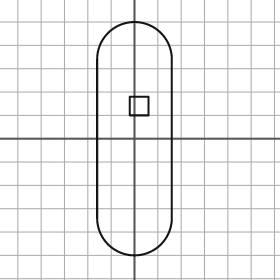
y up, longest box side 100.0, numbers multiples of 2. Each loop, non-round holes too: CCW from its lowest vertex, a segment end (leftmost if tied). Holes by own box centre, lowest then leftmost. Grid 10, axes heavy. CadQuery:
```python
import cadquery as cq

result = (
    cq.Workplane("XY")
    .moveTo(-16.0, -34.0)
    .threePointArc((0.0, -50.0), (16.0, -34.0))
    .lineTo(16.0, 34.0)
    .threePointArc((0.0, 50.0), (-16.0, 34.0))
    .close()
    .moveTo(-2.0, 10.0)
    .lineTo(6.0, 10.0)
    .lineTo(6.0, 18.0)
    .lineTo(-2.0, 18.0)
    .close()
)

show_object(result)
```